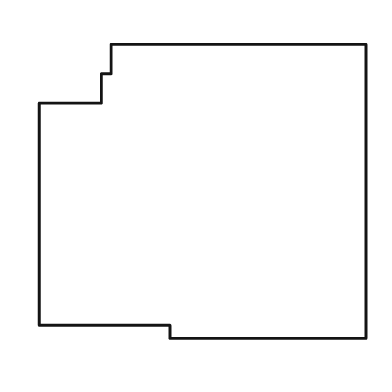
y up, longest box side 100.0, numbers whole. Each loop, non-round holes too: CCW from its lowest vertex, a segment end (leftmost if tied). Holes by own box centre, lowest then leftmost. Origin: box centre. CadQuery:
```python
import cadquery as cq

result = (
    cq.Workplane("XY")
    .moveTo(-10.0, -45.0)
    .lineTo(50.0, -45.0)
    .lineTo(50.0, 45.0)
    .lineTo(-28.0, 45.0)
    .lineTo(-28.0, 36.0)
    .lineTo(-31.0, 36.0)
    .lineTo(-31.0, 27.0)
    .lineTo(-50.0, 27.0)
    .lineTo(-50.0, -41.0)
    .lineTo(-10.0, -41.0)
    .close()
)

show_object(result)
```